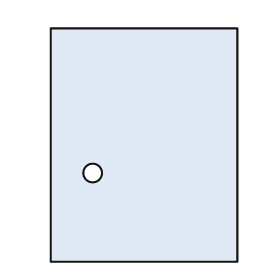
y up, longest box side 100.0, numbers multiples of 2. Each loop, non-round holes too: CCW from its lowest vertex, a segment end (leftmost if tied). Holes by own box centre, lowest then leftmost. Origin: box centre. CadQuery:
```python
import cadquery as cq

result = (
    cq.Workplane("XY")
    .moveTo(-40.0, -50.0)
    .lineTo(40.0, -50.0)
    .lineTo(40.0, 50.0)
    .lineTo(-40.0, 50.0)
    .close()
    .moveTo(-22.0, -12.0)
    .circle(4.0)
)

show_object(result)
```